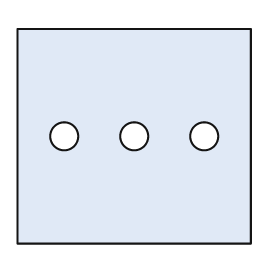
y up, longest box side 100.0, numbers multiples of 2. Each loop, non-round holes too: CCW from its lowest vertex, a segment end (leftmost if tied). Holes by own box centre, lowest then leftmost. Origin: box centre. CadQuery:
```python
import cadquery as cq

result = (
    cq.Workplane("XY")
    .moveTo(-50.0, -46.0)
    .lineTo(50.0, -46.0)
    .lineTo(50.0, 46.0)
    .lineTo(-50.0, 46.0)
    .close()
    .moveTo(-30.0, 0.0)
    .circle(6.0)
    .moveTo(0.0, 0.0)
    .circle(6.0)
    .moveTo(30.0, 0.0)
    .circle(6.0)
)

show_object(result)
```